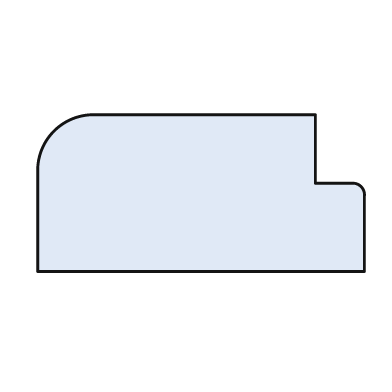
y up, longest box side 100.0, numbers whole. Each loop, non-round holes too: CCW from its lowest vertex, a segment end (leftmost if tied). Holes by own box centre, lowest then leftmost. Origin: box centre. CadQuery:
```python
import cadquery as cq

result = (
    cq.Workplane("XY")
    .moveTo(-50.0, -24.0)
    .lineTo(50.0, -24.0)
    .lineTo(50.0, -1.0)
    .threePointArc((49.0, 2.0), (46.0, 3.0))
    .lineTo(35.0, 3.0)
    .lineTo(35.0, 24.0)
    .lineTo(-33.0, 24.0)
    .threePointArc((-45.0, 19.0), (-50.0, 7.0))
    .close()
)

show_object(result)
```